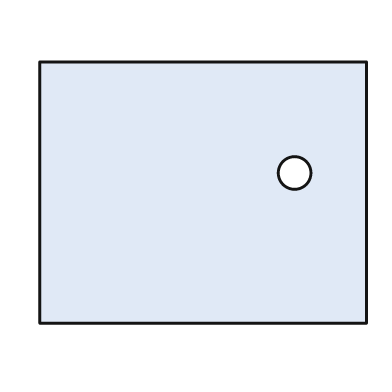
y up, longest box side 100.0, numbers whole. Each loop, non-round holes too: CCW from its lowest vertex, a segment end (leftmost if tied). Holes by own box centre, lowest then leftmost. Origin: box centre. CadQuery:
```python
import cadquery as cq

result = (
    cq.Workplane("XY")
    .moveTo(-50.0, -40.0)
    .lineTo(50.0, -40.0)
    .lineTo(50.0, 40.0)
    .lineTo(-50.0, 40.0)
    .close()
    .moveTo(28.0, 6.0)
    .circle(5.0)
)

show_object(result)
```